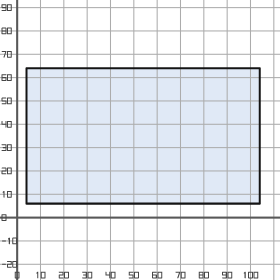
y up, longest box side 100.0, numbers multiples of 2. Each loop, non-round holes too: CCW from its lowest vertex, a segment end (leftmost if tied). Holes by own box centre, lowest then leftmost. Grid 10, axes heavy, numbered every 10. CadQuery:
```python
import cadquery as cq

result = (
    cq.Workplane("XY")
    .moveTo(4.0, 6.0)
    .lineTo(104.0, 6.0)
    .lineTo(104.0, 64.0)
    .lineTo(4.0, 64.0)
    .close()
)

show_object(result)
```